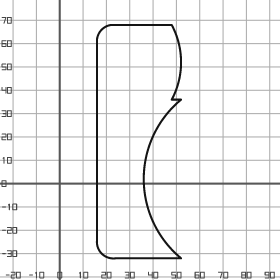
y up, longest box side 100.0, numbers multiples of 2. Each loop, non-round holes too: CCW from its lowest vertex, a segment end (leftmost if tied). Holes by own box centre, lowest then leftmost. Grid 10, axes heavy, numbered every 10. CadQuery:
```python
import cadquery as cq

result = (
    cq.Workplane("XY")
    .moveTo(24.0, -32.0)
    .lineTo(52.0, -32.0)
    .threePointArc((36.0, 2.0), (52.0, 36.0))
    .lineTo(48.0, 36.0)
    .threePointArc((52.0, 52.0), (48.0, 68.0))
    .lineTo(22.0, 68.0)
    .threePointArc((18.0, 66.0), (16.0, 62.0))
    .lineTo(16.0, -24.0)
    .threePointArc((18.0, -30.0), (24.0, -32.0))
    .close()
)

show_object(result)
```